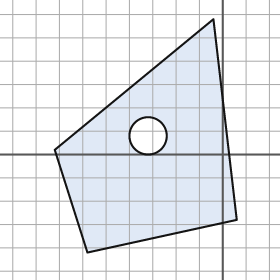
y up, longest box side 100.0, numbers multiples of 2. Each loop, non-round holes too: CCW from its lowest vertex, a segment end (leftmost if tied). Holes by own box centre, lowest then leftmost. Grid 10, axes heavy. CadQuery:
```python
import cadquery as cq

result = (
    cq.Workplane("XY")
    .moveTo(-58.0, -42.0)
    .lineTo(6.0, -28.0)
    .lineTo(-4.0, 58.0)
    .lineTo(-72.0, 2.0)
    .close()
    .moveTo(-32.0, 8.0)
    .circle(8.0)
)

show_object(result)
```